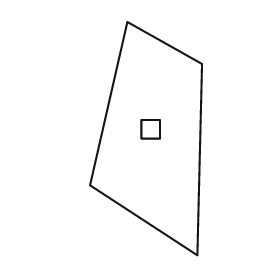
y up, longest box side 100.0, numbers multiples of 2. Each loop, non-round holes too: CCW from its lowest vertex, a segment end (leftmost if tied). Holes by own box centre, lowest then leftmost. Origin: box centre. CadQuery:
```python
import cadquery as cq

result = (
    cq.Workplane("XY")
    .moveTo(22.0, -50.0)
    .lineTo(24.0, 32.0)
    .lineTo(-8.0, 50.0)
    .lineTo(-24.0, -20.0)
    .close()
    .moveTo(-2.0, 0.0)
    .lineTo(6.0, 0.0)
    .lineTo(6.0, 8.0)
    .lineTo(-2.0, 8.0)
    .close()
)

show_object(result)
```